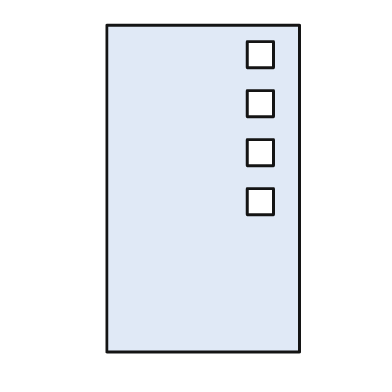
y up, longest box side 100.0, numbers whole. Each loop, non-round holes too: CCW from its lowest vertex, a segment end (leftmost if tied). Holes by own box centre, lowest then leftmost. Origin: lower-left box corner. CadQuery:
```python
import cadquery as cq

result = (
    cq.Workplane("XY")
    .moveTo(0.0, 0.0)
    .lineTo(59.0, 0.0)
    .lineTo(59.0, 100.0)
    .lineTo(0.0, 100.0)
    .close()
    .moveTo(43.0, 42.0)
    .lineTo(51.0, 42.0)
    .lineTo(51.0, 50.0)
    .lineTo(43.0, 50.0)
    .close()
    .moveTo(43.0, 57.0)
    .lineTo(51.0, 57.0)
    .lineTo(51.0, 65.0)
    .lineTo(43.0, 65.0)
    .close()
    .moveTo(43.0, 72.0)
    .lineTo(51.0, 72.0)
    .lineTo(51.0, 80.0)
    .lineTo(43.0, 80.0)
    .close()
    .moveTo(43.0, 87.0)
    .lineTo(51.0, 87.0)
    .lineTo(51.0, 95.0)
    .lineTo(43.0, 95.0)
    .close()
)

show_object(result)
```